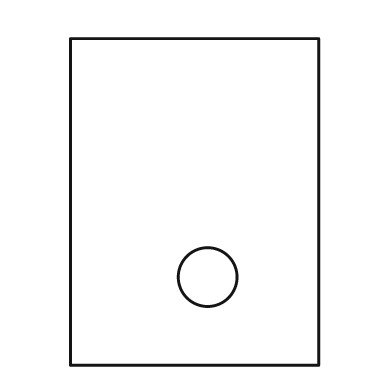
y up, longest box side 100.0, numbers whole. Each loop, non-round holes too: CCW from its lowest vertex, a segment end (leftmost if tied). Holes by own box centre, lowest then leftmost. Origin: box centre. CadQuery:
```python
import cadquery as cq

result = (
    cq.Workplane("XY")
    .moveTo(-38.0, -50.0)
    .lineTo(38.0, -50.0)
    .lineTo(38.0, 50.0)
    .lineTo(-38.0, 50.0)
    .close()
    .moveTo(4.0, -23.0)
    .circle(9.0)
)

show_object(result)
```